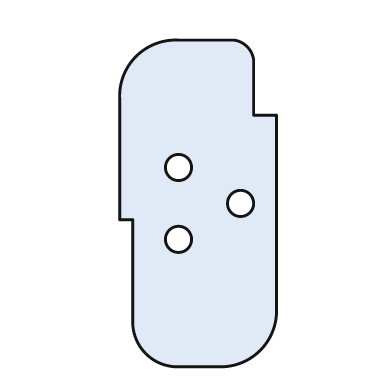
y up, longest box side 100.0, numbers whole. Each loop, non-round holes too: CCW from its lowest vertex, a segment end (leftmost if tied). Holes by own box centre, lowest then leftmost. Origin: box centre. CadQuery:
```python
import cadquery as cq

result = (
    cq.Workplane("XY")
    .moveTo(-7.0, -50.0)
    .lineTo(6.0, -50.0)
    .threePointArc((19.0, -45.0), (24.0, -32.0))
    .lineTo(24.0, 27.0)
    .lineTo(17.0, 27.0)
    .lineTo(17.0, 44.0)
    .threePointArc((15.0, 48.0), (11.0, 50.0))
    .lineTo(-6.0, 50.0)
    .threePointArc((-19.0, 45.0), (-24.0, 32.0))
    .lineTo(-24.0, -5.0)
    .lineTo(-20.0, -5.0)
    .lineTo(-20.0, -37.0)
    .threePointArc((-16.0, -46.0), (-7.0, -50.0))
    .close()
    .moveTo(-6.0, -11.0)
    .circle(4.0)
    .moveTo(13.0, 0.0)
    .circle(4.0)
    .moveTo(-6.0, 11.0)
    .circle(4.0)
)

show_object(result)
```